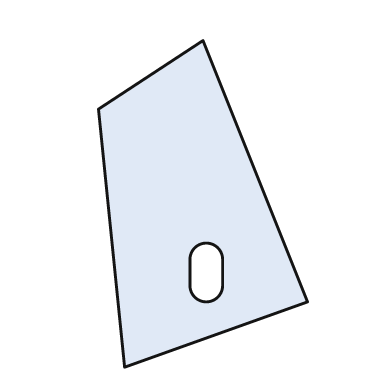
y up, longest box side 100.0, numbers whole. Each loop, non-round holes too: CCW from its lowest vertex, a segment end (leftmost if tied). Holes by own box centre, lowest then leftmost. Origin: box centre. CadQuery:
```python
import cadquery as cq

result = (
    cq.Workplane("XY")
    .moveTo(-24.0, -50.0)
    .lineTo(32.0, -30.0)
    .lineTo(0.0, 50.0)
    .lineTo(-32.0, 29.0)
    .close()
    .moveTo(-4.0, -25.0)
    .threePointArc((1.0, -30.0), (6.0, -25.0))
    .lineTo(6.0, -17.0)
    .threePointArc((1.0, -12.0), (-4.0, -17.0))
    .close()
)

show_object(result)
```